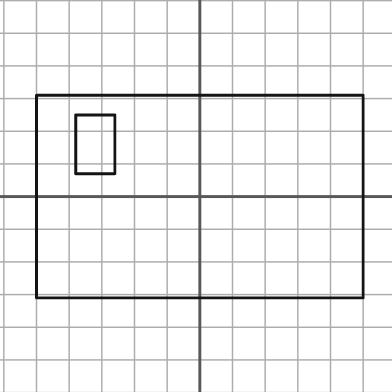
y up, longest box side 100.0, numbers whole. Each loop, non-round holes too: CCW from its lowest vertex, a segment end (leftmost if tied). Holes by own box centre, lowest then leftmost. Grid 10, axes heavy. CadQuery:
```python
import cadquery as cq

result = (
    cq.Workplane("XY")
    .moveTo(-50.0, -31.0)
    .lineTo(50.0, -31.0)
    .lineTo(50.0, 31.0)
    .lineTo(-50.0, 31.0)
    .close()
    .moveTo(-38.0, 7.0)
    .lineTo(-26.0, 7.0)
    .lineTo(-26.0, 25.0)
    .lineTo(-38.0, 25.0)
    .close()
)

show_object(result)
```